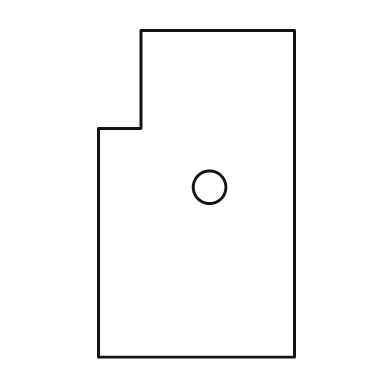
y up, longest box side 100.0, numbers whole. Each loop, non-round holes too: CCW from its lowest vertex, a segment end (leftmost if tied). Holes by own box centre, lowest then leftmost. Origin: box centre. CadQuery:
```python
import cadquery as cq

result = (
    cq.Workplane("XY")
    .moveTo(-30.0, -50.0)
    .lineTo(30.0, -50.0)
    .lineTo(30.0, 50.0)
    .lineTo(-17.0, 50.0)
    .lineTo(-17.0, 20.0)
    .lineTo(-30.0, 20.0)
    .close()
    .moveTo(4.0, 2.0)
    .circle(5.0)
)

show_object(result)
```